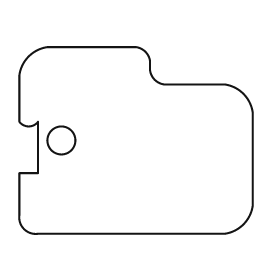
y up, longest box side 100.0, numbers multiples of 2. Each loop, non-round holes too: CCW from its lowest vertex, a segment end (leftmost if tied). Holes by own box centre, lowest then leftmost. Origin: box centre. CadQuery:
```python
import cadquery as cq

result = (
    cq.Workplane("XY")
    .moveTo(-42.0, -40.0)
    .lineTo(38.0, -40.0)
    .threePointArc((46.0, -36.0), (50.0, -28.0))
    .lineTo(50.0, 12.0)
    .threePointArc((46.0, 20.0), (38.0, 24.0))
    .lineTo(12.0, 24.0)
    .threePointArc((8.0, 26.0), (6.0, 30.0))
    .lineTo(6.0, 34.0)
    .threePointArc((4.0, 38.0), (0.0, 40.0))
    .lineTo(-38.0, 40.0)
    .threePointArc((-46.0, 36.0), (-50.0, 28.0))
    .lineTo(-50.0, 8.0)
    .threePointArc((-46.0, 6.0), (-42.0, 8.0))
    .lineTo(-42.0, -14.0)
    .lineTo(-50.0, -14.0)
    .lineTo(-50.0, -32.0)
    .threePointArc((-48.0, -38.0), (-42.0, -40.0))
    .close()
    .moveTo(-32.0, 0.0)
    .circle(6.0)
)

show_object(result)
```